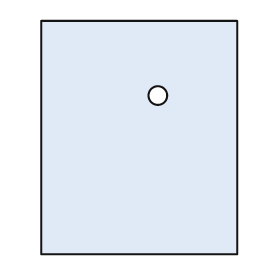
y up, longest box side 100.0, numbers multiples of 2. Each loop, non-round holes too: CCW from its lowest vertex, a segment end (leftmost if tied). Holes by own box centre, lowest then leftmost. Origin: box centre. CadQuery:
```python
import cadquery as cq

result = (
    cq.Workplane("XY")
    .moveTo(-42.0, -50.0)
    .lineTo(42.0, -50.0)
    .lineTo(42.0, 50.0)
    .lineTo(-42.0, 50.0)
    .close()
    .moveTo(8.0, 18.0)
    .circle(4.0)
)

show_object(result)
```